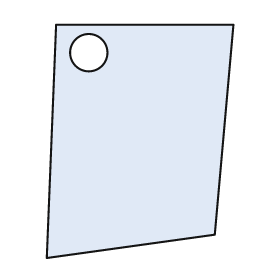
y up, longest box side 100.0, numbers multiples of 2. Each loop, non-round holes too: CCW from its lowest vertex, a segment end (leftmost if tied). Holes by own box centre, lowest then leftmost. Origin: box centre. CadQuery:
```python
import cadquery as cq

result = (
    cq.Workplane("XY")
    .moveTo(-40.0, -50.0)
    .lineTo(32.0, -40.0)
    .lineTo(40.0, 50.0)
    .lineTo(-36.0, 50.0)
    .close()
    .moveTo(-22.0, 38.0)
    .circle(8.0)
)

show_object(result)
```